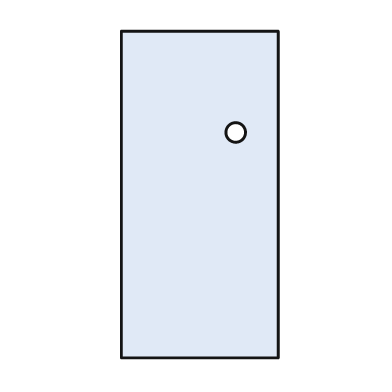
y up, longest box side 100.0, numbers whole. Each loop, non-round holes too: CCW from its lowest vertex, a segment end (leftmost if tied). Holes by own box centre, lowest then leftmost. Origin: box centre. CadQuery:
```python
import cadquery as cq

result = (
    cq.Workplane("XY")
    .moveTo(-24.0, -50.0)
    .lineTo(24.0, -50.0)
    .lineTo(24.0, 50.0)
    .lineTo(-24.0, 50.0)
    .close()
    .moveTo(11.0, 19.0)
    .circle(3.0)
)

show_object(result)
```